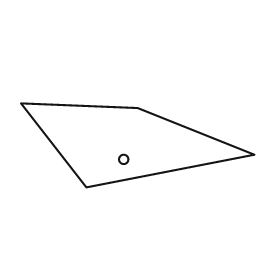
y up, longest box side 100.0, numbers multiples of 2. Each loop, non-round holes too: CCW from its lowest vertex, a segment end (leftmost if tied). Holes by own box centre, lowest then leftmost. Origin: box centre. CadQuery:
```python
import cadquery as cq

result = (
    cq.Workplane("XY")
    .moveTo(-22.0, -18.0)
    .lineTo(50.0, -4.0)
    .lineTo(0.0, 16.0)
    .lineTo(-50.0, 18.0)
    .close()
    .moveTo(-6.0, -6.0)
    .circle(2.0)
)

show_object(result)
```